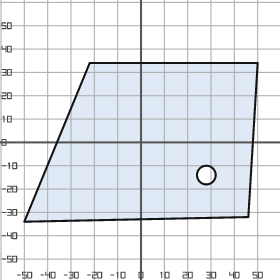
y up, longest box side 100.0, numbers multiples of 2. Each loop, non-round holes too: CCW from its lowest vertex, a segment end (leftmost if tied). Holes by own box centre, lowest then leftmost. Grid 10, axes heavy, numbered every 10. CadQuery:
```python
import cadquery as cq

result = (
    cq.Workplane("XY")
    .moveTo(-50.0, -34.0)
    .lineTo(46.0, -32.0)
    .lineTo(50.0, 34.0)
    .lineTo(-22.0, 34.0)
    .close()
    .moveTo(28.0, -14.0)
    .circle(4.0)
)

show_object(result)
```